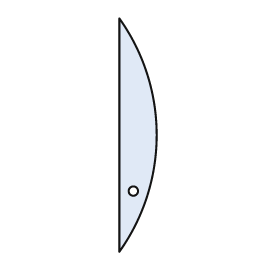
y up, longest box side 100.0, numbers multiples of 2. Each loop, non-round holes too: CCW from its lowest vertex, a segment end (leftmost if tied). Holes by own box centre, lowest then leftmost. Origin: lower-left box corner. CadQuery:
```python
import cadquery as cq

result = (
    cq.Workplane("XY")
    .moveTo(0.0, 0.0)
    .threePointArc((16.0, 50.0), (0.0, 100.0))
    .close()
    .moveTo(6.0, 26.0)
    .circle(2.0)
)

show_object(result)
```